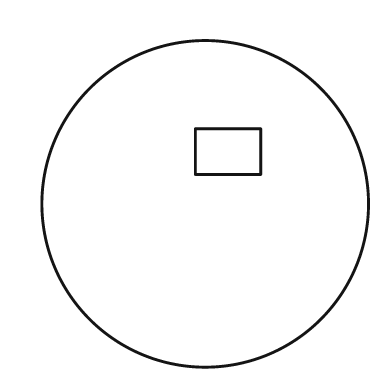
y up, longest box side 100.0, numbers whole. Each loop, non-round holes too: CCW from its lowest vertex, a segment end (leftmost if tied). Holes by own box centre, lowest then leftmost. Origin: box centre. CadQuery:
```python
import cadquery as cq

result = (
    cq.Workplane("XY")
    .moveTo(0.0, 0.0)
    .circle(50.0)
    .moveTo(-3.0, 9.0)
    .lineTo(17.0, 9.0)
    .lineTo(17.0, 23.0)
    .lineTo(-3.0, 23.0)
    .close()
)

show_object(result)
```